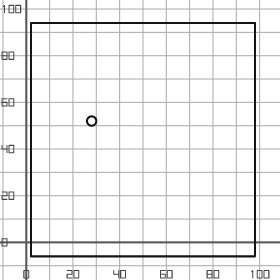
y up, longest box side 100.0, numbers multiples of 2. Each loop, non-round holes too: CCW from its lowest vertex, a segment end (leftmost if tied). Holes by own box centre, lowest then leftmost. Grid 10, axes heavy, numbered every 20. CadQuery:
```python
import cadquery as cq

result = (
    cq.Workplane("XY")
    .moveTo(2.0, -6.0)
    .lineTo(98.0, -6.0)
    .lineTo(98.0, 94.0)
    .lineTo(2.0, 94.0)
    .close()
    .moveTo(28.0, 52.0)
    .circle(2.0)
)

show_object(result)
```